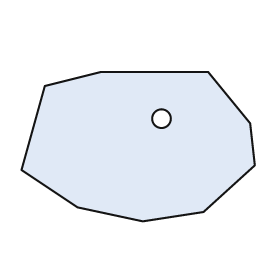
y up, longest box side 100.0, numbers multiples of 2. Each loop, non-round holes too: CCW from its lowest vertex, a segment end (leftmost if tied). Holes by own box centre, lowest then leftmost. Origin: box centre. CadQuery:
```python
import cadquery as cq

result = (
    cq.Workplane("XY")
    .moveTo(2.0, -32.0)
    .lineTo(28.0, -28.0)
    .lineTo(50.0, -8.0)
    .lineTo(48.0, 10.0)
    .lineTo(30.0, 32.0)
    .lineTo(-16.0, 32.0)
    .lineTo(-40.0, 26.0)
    .lineTo(-50.0, -10.0)
    .lineTo(-26.0, -26.0)
    .close()
    .moveTo(10.0, 12.0)
    .circle(4.0)
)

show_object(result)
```